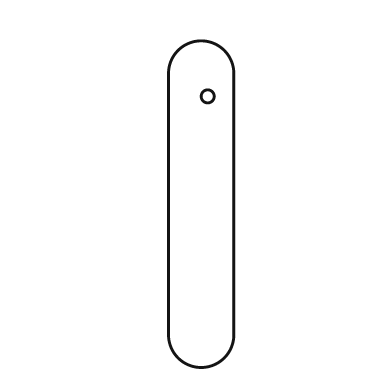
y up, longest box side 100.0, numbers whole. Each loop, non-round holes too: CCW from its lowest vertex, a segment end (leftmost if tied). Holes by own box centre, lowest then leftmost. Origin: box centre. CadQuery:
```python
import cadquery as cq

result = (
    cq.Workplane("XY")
    .moveTo(-10.0, -40.0)
    .threePointArc((0.0, -50.0), (10.0, -40.0))
    .lineTo(10.0, 40.0)
    .threePointArc((0.0, 50.0), (-10.0, 40.0))
    .close()
    .moveTo(2.0, 33.0)
    .circle(2.0)
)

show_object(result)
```